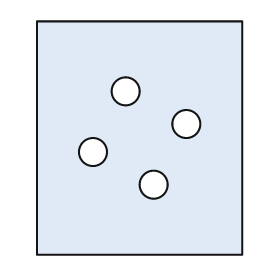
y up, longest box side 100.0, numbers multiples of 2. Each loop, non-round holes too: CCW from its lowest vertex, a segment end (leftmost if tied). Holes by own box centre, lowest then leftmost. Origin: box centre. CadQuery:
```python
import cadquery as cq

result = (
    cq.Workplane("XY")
    .moveTo(-44.0, -50.0)
    .lineTo(44.0, -50.0)
    .lineTo(44.0, 50.0)
    .lineTo(-44.0, 50.0)
    .close()
    .moveTo(6.0, -20.0)
    .circle(6.0)
    .moveTo(-20.0, -6.0)
    .circle(6.0)
    .moveTo(20.0, 6.0)
    .circle(6.0)
    .moveTo(-6.0, 20.0)
    .circle(6.0)
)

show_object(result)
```